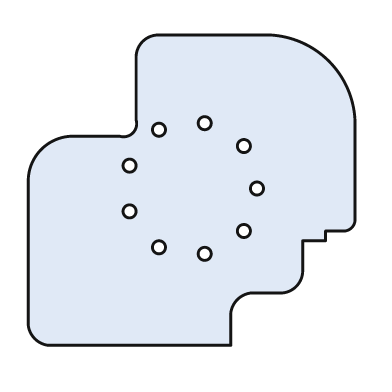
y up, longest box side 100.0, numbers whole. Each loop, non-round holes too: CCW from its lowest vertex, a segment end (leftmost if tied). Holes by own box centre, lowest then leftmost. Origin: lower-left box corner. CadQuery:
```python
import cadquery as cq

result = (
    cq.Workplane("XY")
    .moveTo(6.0, 0.0)
    .lineTo(62.0, 0.0)
    .lineTo(62.0, 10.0)
    .threePointArc((64.0, 14.0), (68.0, 16.0))
    .lineTo(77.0, 16.0)
    .threePointArc((82.0, 18.0), (84.0, 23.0))
    .lineTo(84.0, 32.0)
    .lineTo(91.0, 32.0)
    .lineTo(91.0, 35.0)
    .lineTo(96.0, 35.0)
    .threePointArc((99.0, 36.0), (100.0, 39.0))
    .lineTo(100.0, 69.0)
    .threePointArc((92.0, 87.0), (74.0, 95.0))
    .lineTo(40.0, 95.0)
    .threePointArc((35.0, 93.0), (33.0, 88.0))
    .lineTo(33.0, 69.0)
    .threePointArc((32.0, 65.0), (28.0, 64.0))
    .lineTo(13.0, 64.0)
    .threePointArc((4.0, 60.0), (0.0, 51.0))
    .lineTo(0.0, 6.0)
    .threePointArc((2.0, 2.0), (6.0, 0.0))
    .close()
    .moveTo(54.0, 28.0)
    .circle(2.0)
    .moveTo(40.0, 30.0)
    .circle(2.0)
    .moveTo(66.0, 35.0)
    .circle(2.0)
    .moveTo(31.0, 41.0)
    .circle(2.0)
    .moveTo(70.0, 48.0)
    .circle(2.0)
    .moveTo(31.0, 55.0)
    .circle(2.0)
    .moveTo(66.0, 61.0)
    .circle(2.0)
    .moveTo(40.0, 66.0)
    .circle(2.0)
    .moveTo(54.0, 68.0)
    .circle(2.0)
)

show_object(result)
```